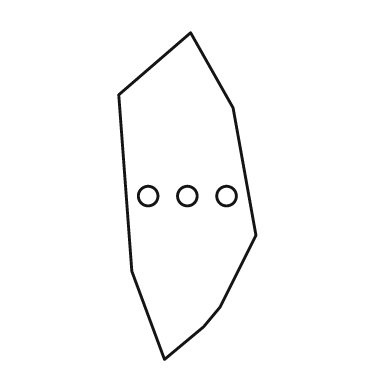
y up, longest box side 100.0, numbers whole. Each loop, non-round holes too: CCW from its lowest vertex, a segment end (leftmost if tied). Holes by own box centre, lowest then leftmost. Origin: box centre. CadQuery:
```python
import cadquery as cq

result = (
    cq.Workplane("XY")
    .moveTo(-7.0, -50.0)
    .lineTo(5.0, -40.0)
    .lineTo(10.0, -34.0)
    .lineTo(21.0, -12.0)
    .lineTo(14.0, 27.0)
    .lineTo(1.0, 50.0)
    .lineTo(-21.0, 31.0)
    .lineTo(-17.0, -23.0)
    .close()
    .moveTo(-12.0, 0.0)
    .circle(3.0)
    .moveTo(0.0, 0.0)
    .circle(3.0)
    .moveTo(12.0, 0.0)
    .circle(3.0)
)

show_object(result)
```